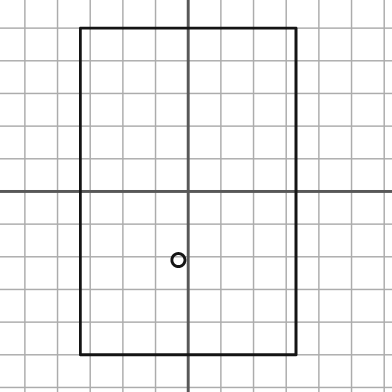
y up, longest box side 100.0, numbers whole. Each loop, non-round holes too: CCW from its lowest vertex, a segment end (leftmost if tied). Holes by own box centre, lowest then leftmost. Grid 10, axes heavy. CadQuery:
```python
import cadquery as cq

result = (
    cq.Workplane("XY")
    .moveTo(-33.0, -50.0)
    .lineTo(33.0, -50.0)
    .lineTo(33.0, 50.0)
    .lineTo(-33.0, 50.0)
    .close()
    .moveTo(-3.0, -21.0)
    .circle(2.0)
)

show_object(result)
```